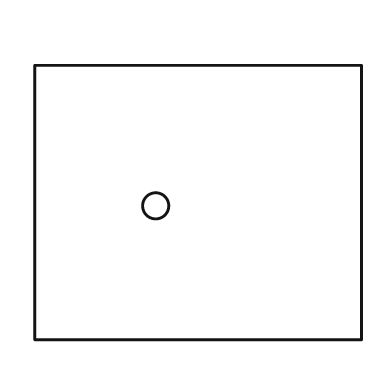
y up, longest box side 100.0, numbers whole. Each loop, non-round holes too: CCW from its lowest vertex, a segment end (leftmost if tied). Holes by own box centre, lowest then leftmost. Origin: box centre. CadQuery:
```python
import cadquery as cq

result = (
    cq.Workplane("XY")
    .moveTo(-50.0, -42.0)
    .lineTo(50.0, -42.0)
    .lineTo(50.0, 42.0)
    .lineTo(-50.0, 42.0)
    .close()
    .moveTo(-13.0, -1.0)
    .circle(4.0)
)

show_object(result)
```